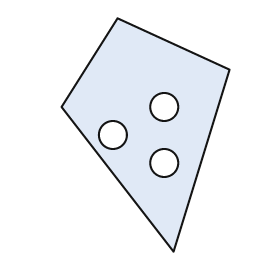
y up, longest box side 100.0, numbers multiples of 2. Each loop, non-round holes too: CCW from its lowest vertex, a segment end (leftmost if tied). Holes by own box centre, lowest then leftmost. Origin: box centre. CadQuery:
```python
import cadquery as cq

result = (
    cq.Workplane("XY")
    .moveTo(12.0, -50.0)
    .lineTo(36.0, 28.0)
    .lineTo(-12.0, 50.0)
    .lineTo(-36.0, 12.0)
    .close()
    .moveTo(8.0, -12.0)
    .circle(6.0)
    .moveTo(-14.0, 0.0)
    .circle(6.0)
    .moveTo(8.0, 12.0)
    .circle(6.0)
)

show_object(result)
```